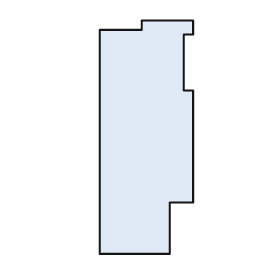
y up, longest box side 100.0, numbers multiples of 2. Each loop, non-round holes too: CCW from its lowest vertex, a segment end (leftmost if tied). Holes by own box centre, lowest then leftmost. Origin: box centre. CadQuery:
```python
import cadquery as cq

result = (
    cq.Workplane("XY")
    .moveTo(-20.0, -50.0)
    .lineTo(10.0, -50.0)
    .lineTo(10.0, -28.0)
    .lineTo(20.0, -28.0)
    .lineTo(20.0, 20.0)
    .lineTo(16.0, 20.0)
    .lineTo(16.0, 44.0)
    .lineTo(20.0, 44.0)
    .lineTo(20.0, 50.0)
    .lineTo(-2.0, 50.0)
    .lineTo(-2.0, 46.0)
    .lineTo(-20.0, 46.0)
    .close()
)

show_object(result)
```